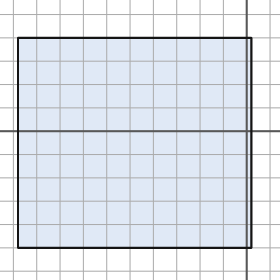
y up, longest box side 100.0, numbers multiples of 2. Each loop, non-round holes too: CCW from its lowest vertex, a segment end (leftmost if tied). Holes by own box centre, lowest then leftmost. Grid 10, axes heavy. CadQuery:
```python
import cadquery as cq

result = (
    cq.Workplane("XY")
    .moveTo(-98.0, -50.0)
    .lineTo(2.0, -50.0)
    .lineTo(2.0, 40.0)
    .lineTo(-98.0, 40.0)
    .close()
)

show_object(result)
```